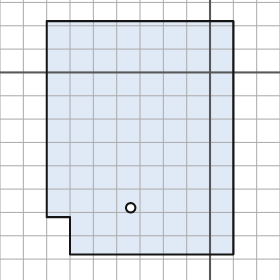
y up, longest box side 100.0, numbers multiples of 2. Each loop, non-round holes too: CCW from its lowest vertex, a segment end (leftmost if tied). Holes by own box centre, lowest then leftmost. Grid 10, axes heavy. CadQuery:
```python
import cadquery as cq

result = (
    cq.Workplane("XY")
    .moveTo(-60.0, -78.0)
    .lineTo(10.0, -78.0)
    .lineTo(10.0, 22.0)
    .lineTo(-70.0, 22.0)
    .lineTo(-70.0, -62.0)
    .lineTo(-60.0, -62.0)
    .close()
    .moveTo(-34.0, -58.0)
    .circle(2.0)
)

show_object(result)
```